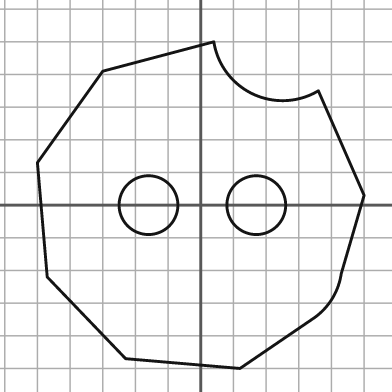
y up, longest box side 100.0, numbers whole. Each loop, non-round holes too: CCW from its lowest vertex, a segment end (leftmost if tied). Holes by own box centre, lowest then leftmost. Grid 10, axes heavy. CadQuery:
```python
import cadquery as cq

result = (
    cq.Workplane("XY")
    .moveTo(12.0, -50.0)
    .lineTo(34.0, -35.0)
    .threePointArc((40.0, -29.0), (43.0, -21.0))
    .lineTo(50.0, 3.0)
    .lineTo(36.0, 35.0)
    .threePointArc((16.0, 34.0), (4.0, 50.0))
    .lineTo(-30.0, 41.0)
    .lineTo(-50.0, 13.0)
    .lineTo(-47.0, -22.0)
    .lineTo(-23.0, -47.0)
    .close()
    .moveTo(-16.0, 0.0)
    .circle(9.0)
    .moveTo(17.0, 0.0)
    .circle(9.0)
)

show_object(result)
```